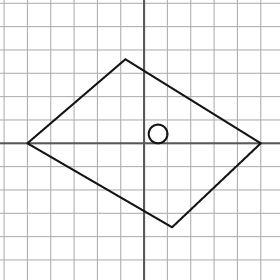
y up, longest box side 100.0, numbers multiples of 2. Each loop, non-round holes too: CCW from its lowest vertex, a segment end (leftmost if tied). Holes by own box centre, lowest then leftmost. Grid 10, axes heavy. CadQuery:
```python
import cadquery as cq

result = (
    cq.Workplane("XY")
    .moveTo(12.0, -36.0)
    .lineTo(50.0, 0.0)
    .lineTo(-8.0, 36.0)
    .lineTo(-50.0, 0.0)
    .close()
    .moveTo(6.0, 4.0)
    .circle(4.0)
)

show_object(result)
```